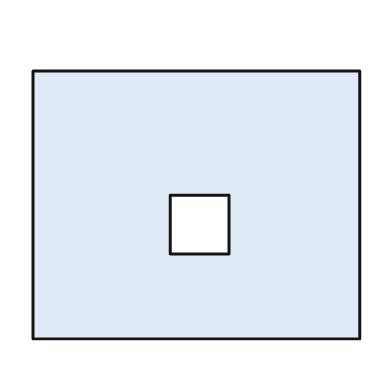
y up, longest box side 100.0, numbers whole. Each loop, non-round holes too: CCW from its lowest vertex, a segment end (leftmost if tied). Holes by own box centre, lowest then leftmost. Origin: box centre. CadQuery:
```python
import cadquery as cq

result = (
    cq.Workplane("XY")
    .moveTo(-50.0, -41.0)
    .lineTo(50.0, -41.0)
    .lineTo(50.0, 41.0)
    .lineTo(-50.0, 41.0)
    .close()
    .moveTo(-8.0, -15.0)
    .lineTo(10.0, -15.0)
    .lineTo(10.0, 3.0)
    .lineTo(-8.0, 3.0)
    .close()
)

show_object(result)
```